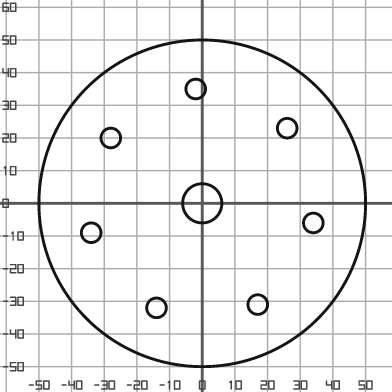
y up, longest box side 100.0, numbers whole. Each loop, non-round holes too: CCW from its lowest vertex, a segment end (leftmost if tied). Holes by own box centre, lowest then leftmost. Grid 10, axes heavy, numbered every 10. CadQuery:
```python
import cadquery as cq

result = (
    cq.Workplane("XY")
    .moveTo(0.0, 0.0)
    .circle(50.0)
    .moveTo(-14.0, -32.0)
    .circle(3.0)
    .moveTo(17.0, -31.0)
    .circle(3.0)
    .moveTo(-34.0, -9.0)
    .circle(3.0)
    .moveTo(34.0, -6.0)
    .circle(3.0)
    .moveTo(0.0, 0.0)
    .circle(6.0)
    .moveTo(-28.0, 20.0)
    .circle(3.0)
    .moveTo(26.0, 23.0)
    .circle(3.0)
    .moveTo(-2.0, 35.0)
    .circle(3.0)
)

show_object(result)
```